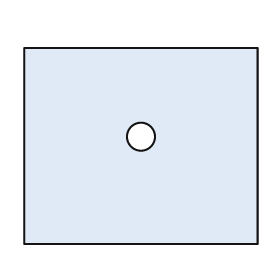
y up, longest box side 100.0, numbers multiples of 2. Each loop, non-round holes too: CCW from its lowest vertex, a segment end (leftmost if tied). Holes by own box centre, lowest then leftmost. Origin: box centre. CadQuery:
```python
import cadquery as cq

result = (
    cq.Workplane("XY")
    .moveTo(-50.0, -42.0)
    .lineTo(50.0, -42.0)
    .lineTo(50.0, 42.0)
    .lineTo(-50.0, 42.0)
    .close()
    .moveTo(0.0, 4.0)
    .circle(6.0)
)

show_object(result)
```